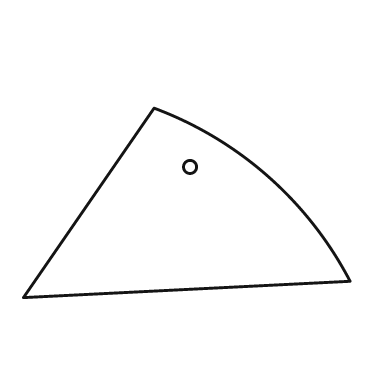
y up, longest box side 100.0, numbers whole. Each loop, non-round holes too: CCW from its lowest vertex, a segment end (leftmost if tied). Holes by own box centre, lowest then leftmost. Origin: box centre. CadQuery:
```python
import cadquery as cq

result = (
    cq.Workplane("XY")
    .moveTo(-50.0, -29.0)
    .lineTo(50.0, -24.0)
    .threePointArc((25.0, 8.0), (-10.0, 29.0))
    .close()
    .moveTo(1.0, 11.0)
    .circle(2.0)
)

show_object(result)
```